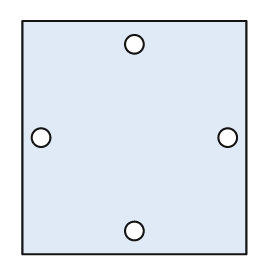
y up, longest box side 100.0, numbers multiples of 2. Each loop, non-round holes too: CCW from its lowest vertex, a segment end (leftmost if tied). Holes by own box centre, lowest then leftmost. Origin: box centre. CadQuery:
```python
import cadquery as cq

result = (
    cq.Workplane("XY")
    .moveTo(-48.0, -50.0)
    .lineTo(48.0, -50.0)
    .lineTo(48.0, 50.0)
    .lineTo(-48.0, 50.0)
    .close()
    .moveTo(0.0, -40.0)
    .circle(4.0)
    .moveTo(-40.0, 0.0)
    .circle(4.0)
    .moveTo(40.0, 0.0)
    .circle(4.0)
    .moveTo(0.0, 40.0)
    .circle(4.0)
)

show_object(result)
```